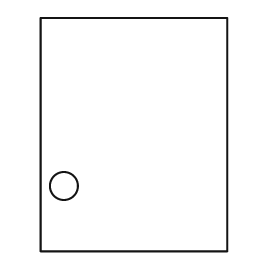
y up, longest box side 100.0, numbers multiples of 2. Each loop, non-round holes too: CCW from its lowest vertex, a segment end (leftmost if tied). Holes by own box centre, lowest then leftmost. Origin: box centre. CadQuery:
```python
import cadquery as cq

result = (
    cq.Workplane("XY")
    .moveTo(-40.0, -50.0)
    .lineTo(40.0, -50.0)
    .lineTo(40.0, 50.0)
    .lineTo(-40.0, 50.0)
    .close()
    .moveTo(-30.0, -22.0)
    .circle(6.0)
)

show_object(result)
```